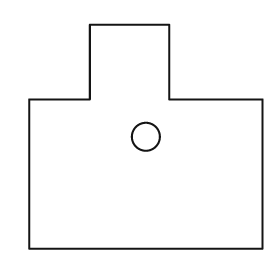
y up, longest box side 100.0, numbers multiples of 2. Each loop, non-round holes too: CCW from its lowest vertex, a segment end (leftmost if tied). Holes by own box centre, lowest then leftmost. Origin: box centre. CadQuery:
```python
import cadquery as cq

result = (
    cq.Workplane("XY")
    .moveTo(-50.0, -48.0)
    .lineTo(50.0, -48.0)
    .lineTo(50.0, 16.0)
    .lineTo(10.0, 16.0)
    .lineTo(10.0, 48.0)
    .lineTo(-24.0, 48.0)
    .lineTo(-24.0, 16.0)
    .lineTo(-50.0, 16.0)
    .close()
    .moveTo(0.0, 0.0)
    .circle(6.0)
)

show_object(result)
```